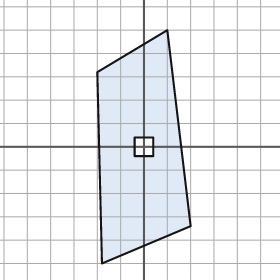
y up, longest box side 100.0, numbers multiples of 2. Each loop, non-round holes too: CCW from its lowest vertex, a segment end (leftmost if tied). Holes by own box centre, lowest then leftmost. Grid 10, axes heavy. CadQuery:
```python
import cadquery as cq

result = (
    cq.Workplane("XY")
    .moveTo(-18.0, -50.0)
    .lineTo(20.0, -34.0)
    .lineTo(10.0, 50.0)
    .lineTo(-20.0, 32.0)
    .close()
    .moveTo(-4.0, -4.0)
    .lineTo(4.0, -4.0)
    .lineTo(4.0, 4.0)
    .lineTo(-4.0, 4.0)
    .close()
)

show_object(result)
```